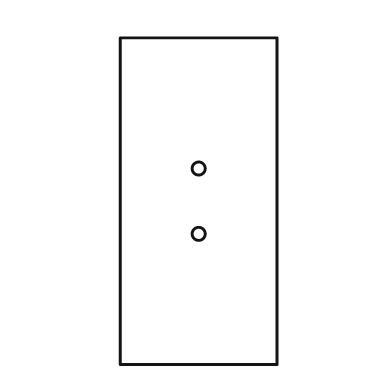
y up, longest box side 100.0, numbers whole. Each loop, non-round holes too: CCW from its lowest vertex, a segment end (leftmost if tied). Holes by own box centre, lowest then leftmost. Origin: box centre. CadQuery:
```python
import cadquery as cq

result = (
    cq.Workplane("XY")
    .moveTo(-24.0, -50.0)
    .lineTo(24.0, -50.0)
    .lineTo(24.0, 50.0)
    .lineTo(-24.0, 50.0)
    .close()
    .moveTo(0.0, -10.0)
    .circle(2.0)
    .moveTo(0.0, 10.0)
    .circle(2.0)
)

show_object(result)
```